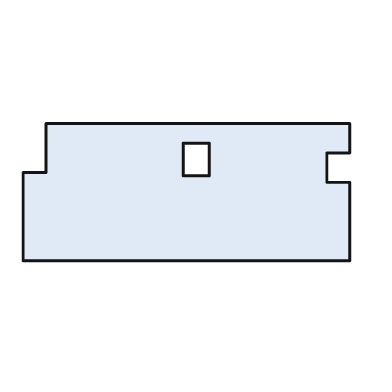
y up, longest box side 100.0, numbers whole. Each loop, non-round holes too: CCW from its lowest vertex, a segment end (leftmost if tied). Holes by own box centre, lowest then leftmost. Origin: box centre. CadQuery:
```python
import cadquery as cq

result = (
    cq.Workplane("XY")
    .moveTo(-50.0, -21.0)
    .lineTo(50.0, -21.0)
    .lineTo(50.0, 3.0)
    .lineTo(43.0, 3.0)
    .lineTo(43.0, 12.0)
    .lineTo(50.0, 12.0)
    .lineTo(50.0, 21.0)
    .lineTo(-43.0, 21.0)
    .lineTo(-43.0, 6.0)
    .lineTo(-50.0, 6.0)
    .close()
    .moveTo(-1.0, 5.0)
    .lineTo(7.0, 5.0)
    .lineTo(7.0, 15.0)
    .lineTo(-1.0, 15.0)
    .close()
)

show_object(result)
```